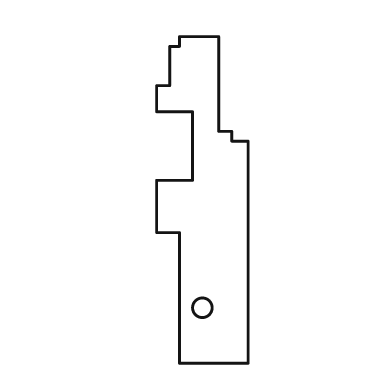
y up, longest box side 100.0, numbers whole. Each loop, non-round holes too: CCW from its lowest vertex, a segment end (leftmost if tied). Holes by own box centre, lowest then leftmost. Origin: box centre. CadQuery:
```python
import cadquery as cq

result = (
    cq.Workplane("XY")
    .moveTo(-7.0, -50.0)
    .lineTo(14.0, -50.0)
    .lineTo(14.0, 18.0)
    .lineTo(9.0, 18.0)
    .lineTo(9.0, 21.0)
    .lineTo(5.0, 21.0)
    .lineTo(5.0, 50.0)
    .lineTo(-7.0, 50.0)
    .lineTo(-7.0, 47.0)
    .lineTo(-10.0, 47.0)
    .lineTo(-10.0, 35.0)
    .lineTo(-14.0, 35.0)
    .lineTo(-14.0, 27.0)
    .lineTo(-3.0, 27.0)
    .lineTo(-3.0, 6.0)
    .lineTo(-14.0, 6.0)
    .lineTo(-14.0, -10.0)
    .lineTo(-7.0, -10.0)
    .close()
    .moveTo(0.0, -33.0)
    .circle(3.0)
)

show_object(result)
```